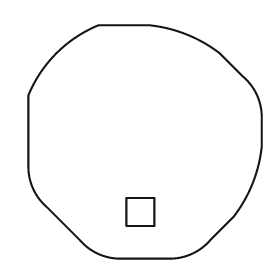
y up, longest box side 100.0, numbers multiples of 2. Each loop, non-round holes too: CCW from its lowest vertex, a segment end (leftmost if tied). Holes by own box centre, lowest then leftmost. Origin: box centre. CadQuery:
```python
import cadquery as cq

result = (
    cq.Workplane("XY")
    .moveTo(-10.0, -50.0)
    .lineTo(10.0, -50.0)
    .threePointArc((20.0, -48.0), (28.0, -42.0))
    .lineTo(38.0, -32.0)
    .threePointArc((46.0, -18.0), (50.0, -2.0))
    .lineTo(50.0, 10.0)
    .threePointArc((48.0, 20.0), (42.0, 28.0))
    .lineTo(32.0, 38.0)
    .threePointArc((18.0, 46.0), (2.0, 50.0))
    .lineTo(-20.0, 50.0)
    .threePointArc((-38.0, 38.0), (-50.0, 20.0))
    .lineTo(-50.0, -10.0)
    .threePointArc((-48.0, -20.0), (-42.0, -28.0))
    .lineTo(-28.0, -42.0)
    .threePointArc((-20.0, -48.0), (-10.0, -50.0))
    .close()
    .moveTo(-8.0, -36.0)
    .lineTo(4.0, -36.0)
    .lineTo(4.0, -24.0)
    .lineTo(-8.0, -24.0)
    .close()
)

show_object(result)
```